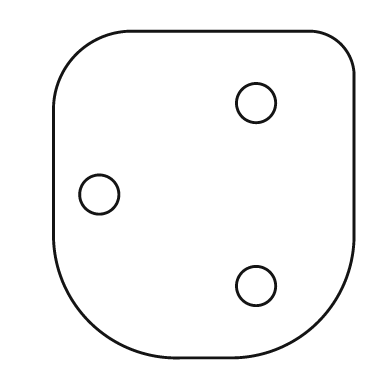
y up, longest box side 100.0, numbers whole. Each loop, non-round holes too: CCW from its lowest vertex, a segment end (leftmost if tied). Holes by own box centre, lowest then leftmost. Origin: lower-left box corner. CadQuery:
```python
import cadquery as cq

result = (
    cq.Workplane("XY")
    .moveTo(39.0, 0.0)
    .lineTo(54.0, 0.0)
    .threePointArc((81.0, 11.0), (92.0, 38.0))
    .lineTo(92.0, 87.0)
    .threePointArc((88.0, 96.0), (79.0, 100.0))
    .lineTo(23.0, 100.0)
    .threePointArc((7.0, 93.0), (0.0, 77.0))
    .lineTo(0.0, 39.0)
    .threePointArc((11.0, 11.0), (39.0, 0.0))
    .close()
    .moveTo(62.0, 22.0)
    .circle(6.0)
    .moveTo(14.0, 50.0)
    .circle(6.0)
    .moveTo(62.0, 78.0)
    .circle(6.0)
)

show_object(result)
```